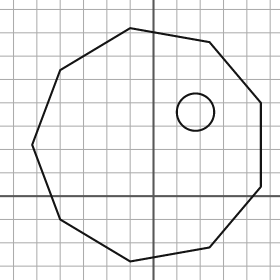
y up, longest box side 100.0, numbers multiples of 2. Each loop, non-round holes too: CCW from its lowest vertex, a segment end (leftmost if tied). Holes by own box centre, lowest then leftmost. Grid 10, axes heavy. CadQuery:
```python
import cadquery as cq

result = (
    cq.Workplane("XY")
    .moveTo(-10.0, -28.0)
    .lineTo(24.0, -22.0)
    .lineTo(46.0, 4.0)
    .lineTo(46.0, 40.0)
    .lineTo(24.0, 66.0)
    .lineTo(-10.0, 72.0)
    .lineTo(-40.0, 54.0)
    .lineTo(-52.0, 22.0)
    .lineTo(-40.0, -10.0)
    .close()
    .moveTo(18.0, 36.0)
    .circle(8.0)
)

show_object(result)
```